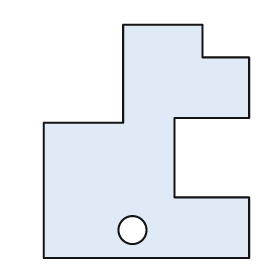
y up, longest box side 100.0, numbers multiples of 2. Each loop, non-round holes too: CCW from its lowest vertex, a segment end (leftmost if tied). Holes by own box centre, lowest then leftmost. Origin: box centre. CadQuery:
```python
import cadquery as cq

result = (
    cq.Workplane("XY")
    .moveTo(-44.0, -50.0)
    .lineTo(44.0, -50.0)
    .lineTo(44.0, -24.0)
    .lineTo(12.0, -24.0)
    .lineTo(12.0, 10.0)
    .lineTo(44.0, 10.0)
    .lineTo(44.0, 36.0)
    .lineTo(24.0, 36.0)
    .lineTo(24.0, 50.0)
    .lineTo(-10.0, 50.0)
    .lineTo(-10.0, 8.0)
    .lineTo(-44.0, 8.0)
    .close()
    .moveTo(-6.0, -38.0)
    .circle(6.0)
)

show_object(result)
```